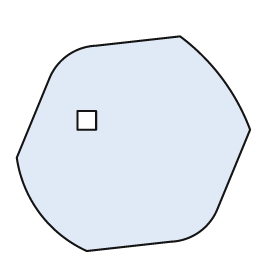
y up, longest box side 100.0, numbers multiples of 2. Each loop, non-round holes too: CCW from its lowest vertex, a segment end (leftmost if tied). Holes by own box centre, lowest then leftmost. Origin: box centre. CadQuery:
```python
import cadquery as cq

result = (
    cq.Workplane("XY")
    .moveTo(-20.0, -46.0)
    .lineTo(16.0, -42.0)
    .threePointArc((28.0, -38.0), (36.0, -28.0))
    .lineTo(50.0, 6.0)
    .threePointArc((38.0, 28.0), (20.0, 46.0))
    .lineTo(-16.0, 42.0)
    .threePointArc((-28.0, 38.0), (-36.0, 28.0))
    .lineTo(-50.0, -6.0)
    .threePointArc((-40.0, -30.0), (-20.0, -46.0))
    .close()
    .moveTo(-24.0, 6.0)
    .lineTo(-16.0, 6.0)
    .lineTo(-16.0, 14.0)
    .lineTo(-24.0, 14.0)
    .close()
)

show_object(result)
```